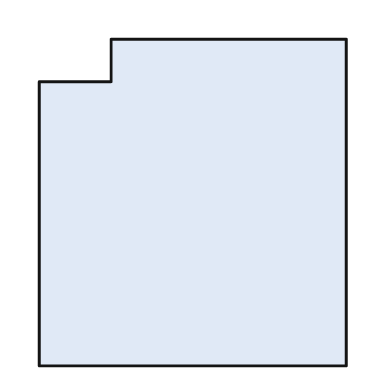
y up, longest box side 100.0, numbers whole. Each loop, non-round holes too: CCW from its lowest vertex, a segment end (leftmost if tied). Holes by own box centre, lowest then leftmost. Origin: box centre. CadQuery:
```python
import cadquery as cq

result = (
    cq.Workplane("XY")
    .moveTo(-47.0, -50.0)
    .lineTo(47.0, -50.0)
    .lineTo(47.0, 50.0)
    .lineTo(-25.0, 50.0)
    .lineTo(-25.0, 37.0)
    .lineTo(-47.0, 37.0)
    .close()
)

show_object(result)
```